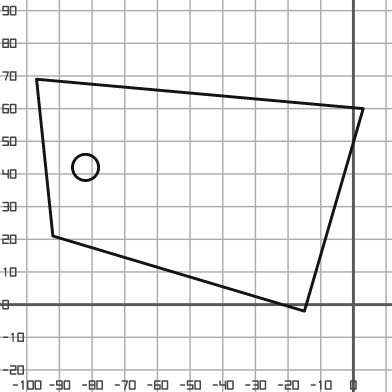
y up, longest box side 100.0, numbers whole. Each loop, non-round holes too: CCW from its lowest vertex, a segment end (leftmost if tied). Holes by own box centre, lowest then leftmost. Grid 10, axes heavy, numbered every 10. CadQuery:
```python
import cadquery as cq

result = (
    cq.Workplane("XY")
    .moveTo(-15.0, -2.0)
    .lineTo(3.0, 60.0)
    .lineTo(-97.0, 69.0)
    .lineTo(-92.0, 21.0)
    .close()
    .moveTo(-82.0, 42.0)
    .circle(4.0)
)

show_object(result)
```